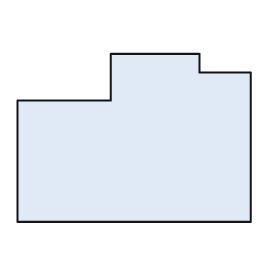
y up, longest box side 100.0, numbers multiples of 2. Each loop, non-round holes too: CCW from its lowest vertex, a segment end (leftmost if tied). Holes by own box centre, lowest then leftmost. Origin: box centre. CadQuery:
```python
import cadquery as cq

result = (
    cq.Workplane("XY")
    .moveTo(-50.0, -36.0)
    .lineTo(50.0, -36.0)
    .lineTo(50.0, 28.0)
    .lineTo(28.0, 28.0)
    .lineTo(28.0, 36.0)
    .lineTo(-10.0, 36.0)
    .lineTo(-10.0, 16.0)
    .lineTo(-50.0, 16.0)
    .close()
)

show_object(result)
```